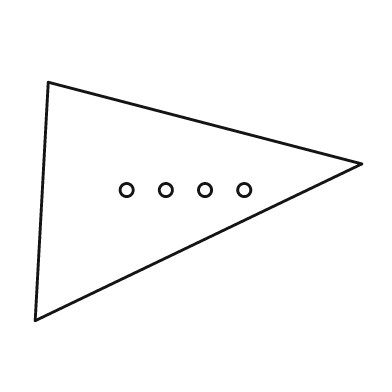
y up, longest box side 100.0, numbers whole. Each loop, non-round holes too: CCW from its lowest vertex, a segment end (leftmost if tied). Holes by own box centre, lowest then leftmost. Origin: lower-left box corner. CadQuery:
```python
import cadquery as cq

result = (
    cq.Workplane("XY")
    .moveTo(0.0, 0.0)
    .lineTo(100.0, 48.0)
    .lineTo(4.0, 73.0)
    .close()
    .moveTo(28.0, 40.0)
    .circle(2.0)
    .moveTo(40.0, 40.0)
    .circle(2.0)
    .moveTo(52.0, 40.0)
    .circle(2.0)
    .moveTo(64.0, 40.0)
    .circle(2.0)
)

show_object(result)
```